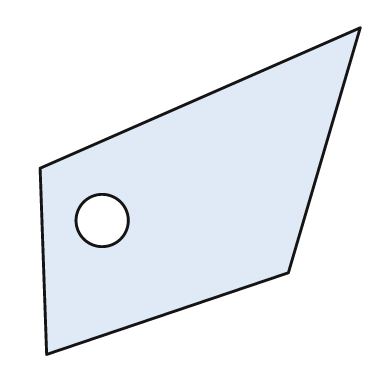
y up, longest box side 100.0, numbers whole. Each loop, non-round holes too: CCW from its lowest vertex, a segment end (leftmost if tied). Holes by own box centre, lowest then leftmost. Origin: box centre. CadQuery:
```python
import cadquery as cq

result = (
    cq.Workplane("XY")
    .moveTo(-47.0, -50.0)
    .lineTo(27.0, -25.0)
    .lineTo(49.0, 50.0)
    .lineTo(-49.0, 7.0)
    .close()
    .moveTo(-30.0, -9.0)
    .circle(8.0)
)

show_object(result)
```